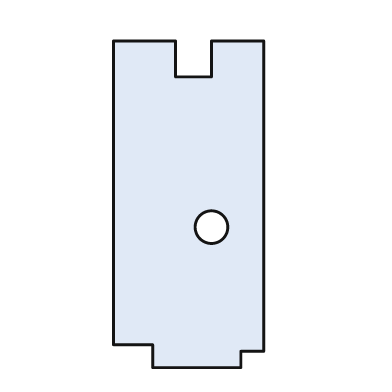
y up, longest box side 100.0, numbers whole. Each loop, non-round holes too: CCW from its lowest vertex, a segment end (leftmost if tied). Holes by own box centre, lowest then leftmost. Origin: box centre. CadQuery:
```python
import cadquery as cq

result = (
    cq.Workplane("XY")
    .moveTo(-11.0, -50.0)
    .lineTo(16.0, -50.0)
    .lineTo(16.0, -45.0)
    .lineTo(23.0, -45.0)
    .lineTo(23.0, 50.0)
    .lineTo(7.0, 50.0)
    .lineTo(7.0, 39.0)
    .lineTo(-4.0, 39.0)
    .lineTo(-4.0, 50.0)
    .lineTo(-23.0, 50.0)
    .lineTo(-23.0, -43.0)
    .lineTo(-11.0, -43.0)
    .close()
    .moveTo(7.0, -7.0)
    .circle(5.0)
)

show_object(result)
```